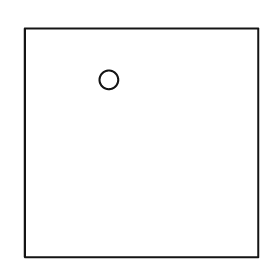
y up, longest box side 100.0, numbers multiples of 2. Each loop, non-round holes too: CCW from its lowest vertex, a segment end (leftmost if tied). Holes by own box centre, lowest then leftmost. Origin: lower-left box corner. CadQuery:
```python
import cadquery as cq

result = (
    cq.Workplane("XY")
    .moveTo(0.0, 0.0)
    .lineTo(100.0, 0.0)
    .lineTo(100.0, 98.0)
    .lineTo(0.0, 98.0)
    .close()
    .moveTo(36.0, 76.0)
    .circle(4.0)
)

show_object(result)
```